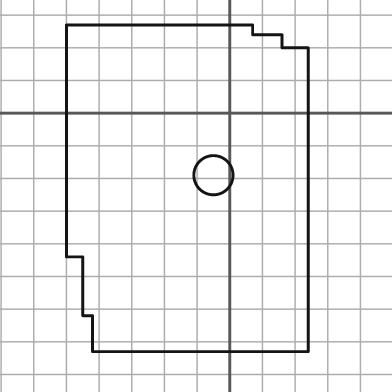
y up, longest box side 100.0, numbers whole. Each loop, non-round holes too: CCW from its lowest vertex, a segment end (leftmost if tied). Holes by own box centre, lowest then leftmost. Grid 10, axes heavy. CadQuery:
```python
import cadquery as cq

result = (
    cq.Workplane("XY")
    .moveTo(-42.0, -73.0)
    .lineTo(24.0, -73.0)
    .lineTo(24.0, 20.0)
    .lineTo(16.0, 20.0)
    .lineTo(16.0, 24.0)
    .lineTo(7.0, 24.0)
    .lineTo(7.0, 27.0)
    .lineTo(-50.0, 27.0)
    .lineTo(-50.0, -44.0)
    .lineTo(-45.0, -44.0)
    .lineTo(-45.0, -62.0)
    .lineTo(-42.0, -62.0)
    .close()
    .moveTo(-5.0, -19.0)
    .circle(6.0)
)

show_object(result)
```